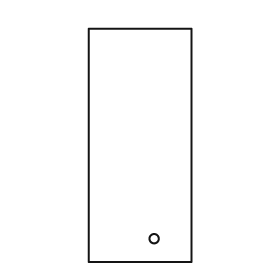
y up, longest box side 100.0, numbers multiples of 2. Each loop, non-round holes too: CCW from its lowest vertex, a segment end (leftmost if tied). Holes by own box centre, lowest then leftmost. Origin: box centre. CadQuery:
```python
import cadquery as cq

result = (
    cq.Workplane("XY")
    .moveTo(-22.0, -50.0)
    .lineTo(22.0, -50.0)
    .lineTo(22.0, 50.0)
    .lineTo(-22.0, 50.0)
    .close()
    .moveTo(6.0, -40.0)
    .circle(2.0)
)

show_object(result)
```